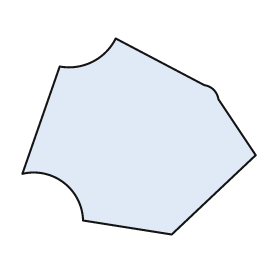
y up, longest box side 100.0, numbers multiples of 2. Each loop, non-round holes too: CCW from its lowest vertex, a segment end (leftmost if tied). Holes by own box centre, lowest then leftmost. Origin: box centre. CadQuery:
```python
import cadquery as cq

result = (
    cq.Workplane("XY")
    .moveTo(14.0, -42.0)
    .lineTo(50.0, -8.0)
    .lineTo(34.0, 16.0)
    .threePointArc((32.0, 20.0), (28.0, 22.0))
    .lineTo(-10.0, 42.0)
    .threePointArc((-20.0, 32.0), (-34.0, 30.0))
    .lineTo(-50.0, -16.0)
    .threePointArc((-32.0, -20.0), (-24.0, -36.0))
    .close()
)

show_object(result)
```